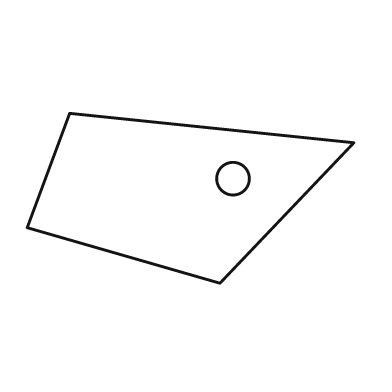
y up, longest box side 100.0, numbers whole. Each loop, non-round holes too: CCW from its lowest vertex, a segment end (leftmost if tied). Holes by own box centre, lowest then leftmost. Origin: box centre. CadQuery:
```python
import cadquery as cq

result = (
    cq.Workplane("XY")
    .moveTo(9.0, -26.0)
    .lineTo(50.0, 17.0)
    .lineTo(-37.0, 26.0)
    .lineTo(-50.0, -9.0)
    .close()
    .moveTo(13.0, 6.0)
    .circle(5.0)
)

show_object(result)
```